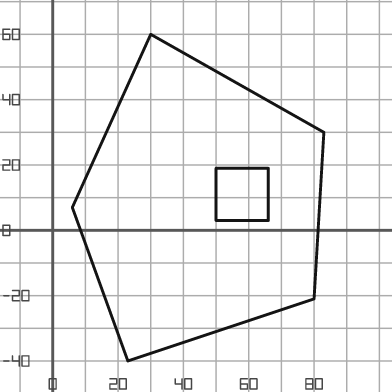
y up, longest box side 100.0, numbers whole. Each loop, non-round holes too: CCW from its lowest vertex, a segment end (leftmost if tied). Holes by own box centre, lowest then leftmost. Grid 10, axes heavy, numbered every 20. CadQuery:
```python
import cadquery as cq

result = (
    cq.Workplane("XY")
    .moveTo(23.0, -40.0)
    .lineTo(80.0, -21.0)
    .lineTo(83.0, 30.0)
    .lineTo(30.0, 60.0)
    .lineTo(6.0, 7.0)
    .close()
    .moveTo(50.0, 3.0)
    .lineTo(66.0, 3.0)
    .lineTo(66.0, 19.0)
    .lineTo(50.0, 19.0)
    .close()
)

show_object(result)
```